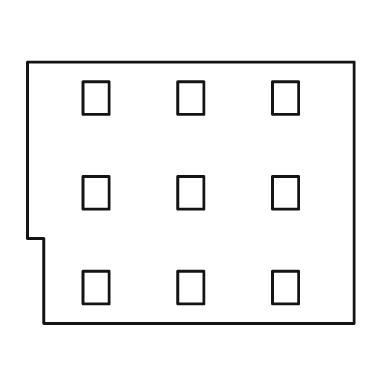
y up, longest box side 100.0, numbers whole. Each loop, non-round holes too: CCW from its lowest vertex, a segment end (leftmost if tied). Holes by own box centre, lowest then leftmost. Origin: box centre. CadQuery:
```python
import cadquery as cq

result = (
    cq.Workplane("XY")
    .moveTo(-45.0, -40.0)
    .lineTo(50.0, -40.0)
    .lineTo(50.0, 40.0)
    .lineTo(-50.0, 40.0)
    .lineTo(-50.0, -14.0)
    .lineTo(-45.0, -14.0)
    .close()
    .moveTo(-33.0, -34.0)
    .lineTo(-25.0, -34.0)
    .lineTo(-25.0, -24.0)
    .lineTo(-33.0, -24.0)
    .close()
    .moveTo(-4.0, -34.0)
    .lineTo(4.0, -34.0)
    .lineTo(4.0, -24.0)
    .lineTo(-4.0, -24.0)
    .close()
    .moveTo(25.0, -34.0)
    .lineTo(33.0, -34.0)
    .lineTo(33.0, -24.0)
    .lineTo(25.0, -24.0)
    .close()
    .moveTo(-33.0, -5.0)
    .lineTo(-25.0, -5.0)
    .lineTo(-25.0, 5.0)
    .lineTo(-33.0, 5.0)
    .close()
    .moveTo(-4.0, -5.0)
    .lineTo(4.0, -5.0)
    .lineTo(4.0, 5.0)
    .lineTo(-4.0, 5.0)
    .close()
    .moveTo(25.0, -5.0)
    .lineTo(33.0, -5.0)
    .lineTo(33.0, 5.0)
    .lineTo(25.0, 5.0)
    .close()
    .moveTo(-33.0, 24.0)
    .lineTo(-25.0, 24.0)
    .lineTo(-25.0, 34.0)
    .lineTo(-33.0, 34.0)
    .close()
    .moveTo(-4.0, 24.0)
    .lineTo(4.0, 24.0)
    .lineTo(4.0, 34.0)
    .lineTo(-4.0, 34.0)
    .close()
    .moveTo(25.0, 24.0)
    .lineTo(33.0, 24.0)
    .lineTo(33.0, 34.0)
    .lineTo(25.0, 34.0)
    .close()
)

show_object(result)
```